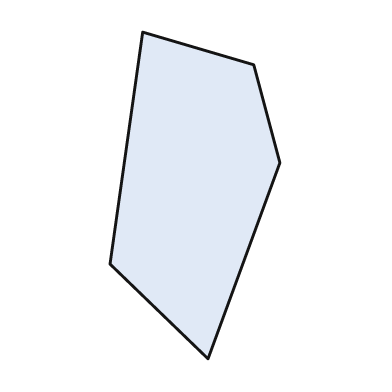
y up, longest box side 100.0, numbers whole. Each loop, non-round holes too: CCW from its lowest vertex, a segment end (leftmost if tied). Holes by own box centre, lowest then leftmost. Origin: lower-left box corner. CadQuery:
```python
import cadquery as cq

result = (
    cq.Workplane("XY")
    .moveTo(30.0, 0.0)
    .lineTo(52.0, 60.0)
    .lineTo(44.0, 90.0)
    .lineTo(10.0, 100.0)
    .lineTo(0.0, 29.0)
    .close()
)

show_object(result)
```